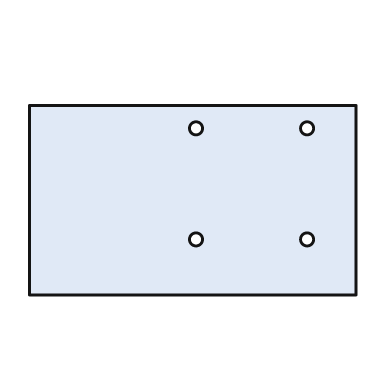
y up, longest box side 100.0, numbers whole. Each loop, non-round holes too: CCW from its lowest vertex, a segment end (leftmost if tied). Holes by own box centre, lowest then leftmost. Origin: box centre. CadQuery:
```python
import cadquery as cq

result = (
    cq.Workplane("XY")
    .moveTo(-50.0, -29.0)
    .lineTo(50.0, -29.0)
    .lineTo(50.0, 29.0)
    .lineTo(-50.0, 29.0)
    .close()
    .moveTo(1.0, -12.0)
    .circle(2.0)
    .moveTo(35.0, -12.0)
    .circle(2.0)
    .moveTo(1.0, 22.0)
    .circle(2.0)
    .moveTo(35.0, 22.0)
    .circle(2.0)
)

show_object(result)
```